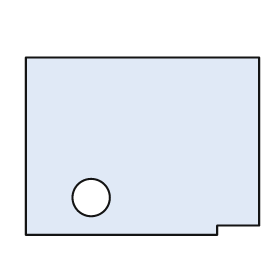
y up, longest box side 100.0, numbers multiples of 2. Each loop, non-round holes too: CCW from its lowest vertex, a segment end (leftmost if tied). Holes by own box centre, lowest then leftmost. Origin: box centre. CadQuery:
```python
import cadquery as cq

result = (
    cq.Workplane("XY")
    .moveTo(-50.0, -38.0)
    .lineTo(32.0, -38.0)
    .lineTo(32.0, -34.0)
    .lineTo(50.0, -34.0)
    .lineTo(50.0, 38.0)
    .lineTo(-50.0, 38.0)
    .close()
    .moveTo(-22.0, -22.0)
    .circle(8.0)
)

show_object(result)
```